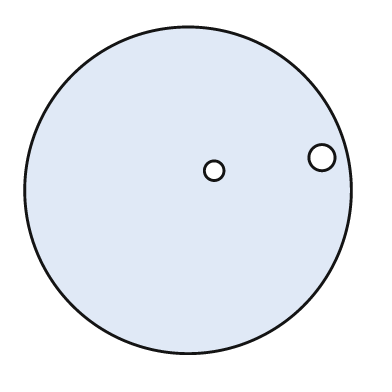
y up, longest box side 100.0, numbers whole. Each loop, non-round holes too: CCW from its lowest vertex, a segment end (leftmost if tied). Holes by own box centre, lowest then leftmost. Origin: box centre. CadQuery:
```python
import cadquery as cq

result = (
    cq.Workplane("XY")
    .moveTo(0.0, 0.0)
    .circle(50.0)
    .moveTo(8.0, 6.0)
    .circle(3.0)
    .moveTo(41.0, 10.0)
    .circle(4.0)
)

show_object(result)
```